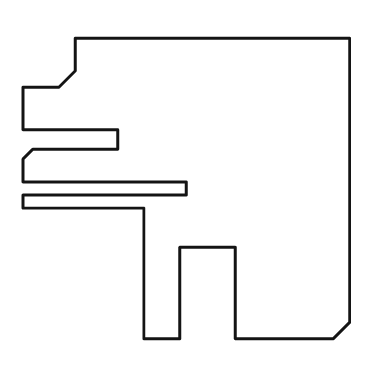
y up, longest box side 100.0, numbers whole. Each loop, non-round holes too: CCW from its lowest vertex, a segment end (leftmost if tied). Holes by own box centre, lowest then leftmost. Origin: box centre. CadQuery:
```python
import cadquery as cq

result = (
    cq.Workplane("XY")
    .moveTo(-13.0, -46.0)
    .lineTo(-2.0, -46.0)
    .lineTo(-2.0, -18.0)
    .lineTo(15.0, -18.0)
    .lineTo(15.0, -46.0)
    .lineTo(45.0, -46.0)
    .lineTo(50.0, -41.0)
    .lineTo(50.0, 46.0)
    .lineTo(-34.0, 46.0)
    .lineTo(-34.0, 36.0)
    .lineTo(-39.0, 31.0)
    .lineTo(-50.0, 31.0)
    .lineTo(-50.0, 18.0)
    .lineTo(-21.0, 18.0)
    .lineTo(-21.0, 12.0)
    .lineTo(-47.0, 12.0)
    .lineTo(-50.0, 9.0)
    .lineTo(-50.0, 2.0)
    .lineTo(0.0, 2.0)
    .lineTo(0.0, -2.0)
    .lineTo(-50.0, -2.0)
    .lineTo(-50.0, -6.0)
    .lineTo(-13.0, -6.0)
    .close()
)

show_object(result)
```